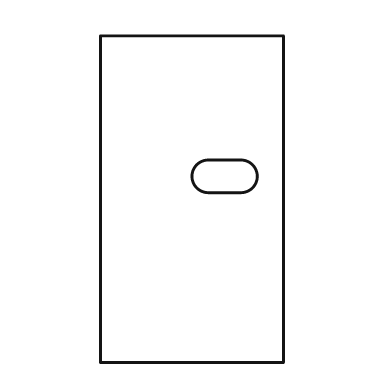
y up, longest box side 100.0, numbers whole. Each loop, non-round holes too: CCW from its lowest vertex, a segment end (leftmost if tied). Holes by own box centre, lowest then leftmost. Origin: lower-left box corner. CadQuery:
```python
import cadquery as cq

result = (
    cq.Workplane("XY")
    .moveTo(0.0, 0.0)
    .lineTo(56.0, 0.0)
    .lineTo(56.0, 100.0)
    .lineTo(0.0, 100.0)
    .close()
    .moveTo(33.0, 52.0)
    .lineTo(43.0, 52.0)
    .threePointArc((48.0, 57.0), (43.0, 62.0))
    .lineTo(33.0, 62.0)
    .threePointArc((28.0, 57.0), (33.0, 52.0))
    .close()
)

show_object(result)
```